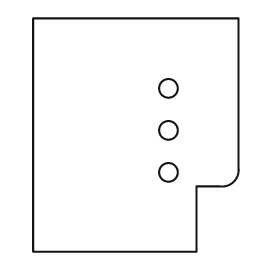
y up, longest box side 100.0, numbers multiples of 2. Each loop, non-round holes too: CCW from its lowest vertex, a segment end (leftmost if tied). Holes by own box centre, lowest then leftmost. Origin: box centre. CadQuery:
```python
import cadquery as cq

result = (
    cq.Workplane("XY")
    .moveTo(-44.0, -50.0)
    .lineTo(26.0, -50.0)
    .lineTo(26.0, -22.0)
    .lineTo(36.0, -22.0)
    .threePointArc((42.0, -20.0), (44.0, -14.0))
    .lineTo(44.0, 50.0)
    .lineTo(-44.0, 50.0)
    .close()
    .moveTo(14.0, -16.0)
    .circle(4.0)
    .moveTo(14.0, 2.0)
    .circle(4.0)
    .moveTo(14.0, 20.0)
    .circle(4.0)
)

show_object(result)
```